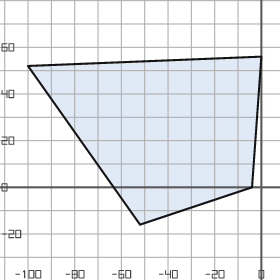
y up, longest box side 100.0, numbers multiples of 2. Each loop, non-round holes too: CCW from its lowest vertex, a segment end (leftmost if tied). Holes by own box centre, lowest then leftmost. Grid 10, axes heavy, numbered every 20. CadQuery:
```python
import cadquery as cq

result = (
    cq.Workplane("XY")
    .moveTo(-52.0, -16.0)
    .lineTo(-4.0, 0.0)
    .lineTo(0.0, 56.0)
    .lineTo(-100.0, 52.0)
    .close()
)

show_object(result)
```